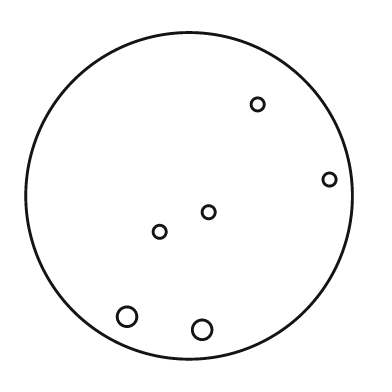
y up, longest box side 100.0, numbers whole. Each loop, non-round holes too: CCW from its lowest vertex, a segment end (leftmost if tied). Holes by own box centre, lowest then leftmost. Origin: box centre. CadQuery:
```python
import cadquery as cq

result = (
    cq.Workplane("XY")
    .moveTo(0.0, 0.0)
    .circle(50.0)
    .moveTo(4.0, -41.0)
    .circle(3.0)
    .moveTo(-19.0, -37.0)
    .circle(3.0)
    .moveTo(-9.0, -11.0)
    .circle(2.0)
    .moveTo(6.0, -5.0)
    .circle(2.0)
    .moveTo(43.0, 5.0)
    .circle(2.0)
    .moveTo(21.0, 28.0)
    .circle(2.0)
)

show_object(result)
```